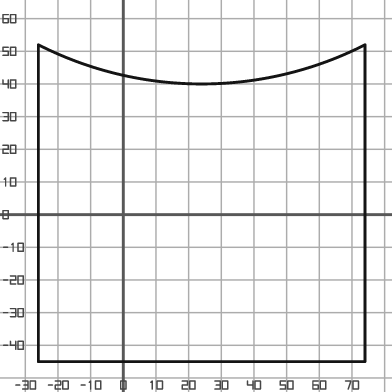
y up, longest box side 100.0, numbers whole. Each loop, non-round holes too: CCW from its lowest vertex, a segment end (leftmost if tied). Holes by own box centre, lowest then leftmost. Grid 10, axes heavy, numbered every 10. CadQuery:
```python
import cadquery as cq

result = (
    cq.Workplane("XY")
    .moveTo(-26.0, -45.0)
    .lineTo(74.0, -45.0)
    .lineTo(74.0, 52.0)
    .threePointArc((24.0, 40.0), (-26.0, 52.0))
    .close()
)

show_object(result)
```